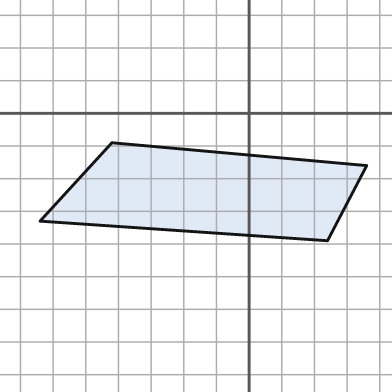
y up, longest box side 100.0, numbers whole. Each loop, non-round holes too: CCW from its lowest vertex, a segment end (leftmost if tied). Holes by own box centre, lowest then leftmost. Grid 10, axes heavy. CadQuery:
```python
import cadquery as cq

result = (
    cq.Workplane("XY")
    .moveTo(24.0, -39.0)
    .lineTo(36.0, -16.0)
    .lineTo(-42.0, -9.0)
    .lineTo(-64.0, -33.0)
    .close()
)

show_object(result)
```